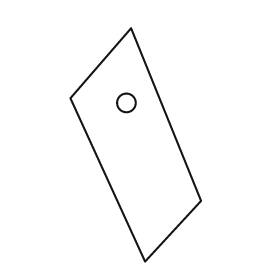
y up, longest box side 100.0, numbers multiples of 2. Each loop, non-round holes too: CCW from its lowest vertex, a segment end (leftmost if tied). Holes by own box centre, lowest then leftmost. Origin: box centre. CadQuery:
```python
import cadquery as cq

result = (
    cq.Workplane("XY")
    .moveTo(4.0, -50.0)
    .lineTo(28.0, -24.0)
    .lineTo(-2.0, 50.0)
    .lineTo(-28.0, 20.0)
    .close()
    .moveTo(-4.0, 18.0)
    .circle(4.0)
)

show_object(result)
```